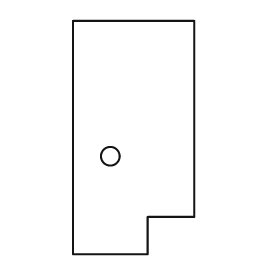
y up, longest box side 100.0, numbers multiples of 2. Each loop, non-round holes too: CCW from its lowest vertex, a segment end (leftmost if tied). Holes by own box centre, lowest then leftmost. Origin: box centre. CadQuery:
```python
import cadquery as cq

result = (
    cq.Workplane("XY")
    .moveTo(-26.0, -50.0)
    .lineTo(6.0, -50.0)
    .lineTo(6.0, -34.0)
    .lineTo(26.0, -34.0)
    .lineTo(26.0, 50.0)
    .lineTo(-26.0, 50.0)
    .close()
    .moveTo(-10.0, -8.0)
    .circle(4.0)
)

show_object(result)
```